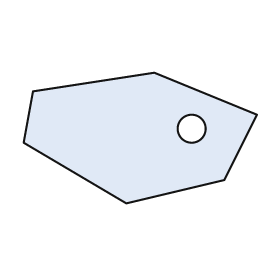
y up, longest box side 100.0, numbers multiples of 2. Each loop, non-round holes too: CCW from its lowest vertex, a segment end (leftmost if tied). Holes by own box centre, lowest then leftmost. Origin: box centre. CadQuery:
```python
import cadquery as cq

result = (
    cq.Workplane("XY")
    .moveTo(-6.0, -28.0)
    .lineTo(36.0, -18.0)
    .lineTo(50.0, 10.0)
    .lineTo(6.0, 28.0)
    .lineTo(-46.0, 20.0)
    .lineTo(-50.0, -2.0)
    .close()
    .moveTo(22.0, 4.0)
    .circle(6.0)
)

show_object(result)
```